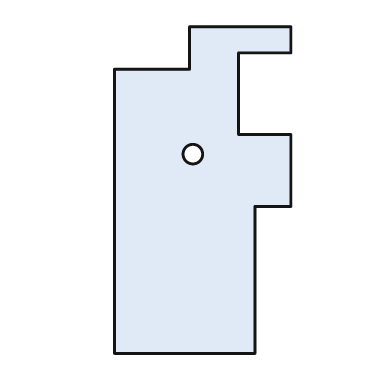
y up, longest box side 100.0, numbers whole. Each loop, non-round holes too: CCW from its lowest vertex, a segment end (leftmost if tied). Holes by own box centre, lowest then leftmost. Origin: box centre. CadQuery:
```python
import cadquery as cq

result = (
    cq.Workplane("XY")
    .moveTo(-27.0, -50.0)
    .lineTo(16.0, -50.0)
    .lineTo(16.0, -5.0)
    .lineTo(27.0, -5.0)
    .lineTo(27.0, 17.0)
    .lineTo(11.0, 17.0)
    .lineTo(11.0, 42.0)
    .lineTo(27.0, 42.0)
    .lineTo(27.0, 50.0)
    .lineTo(-4.0, 50.0)
    .lineTo(-4.0, 37.0)
    .lineTo(-27.0, 37.0)
    .close()
    .moveTo(-3.0, 11.0)
    .circle(3.0)
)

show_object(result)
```